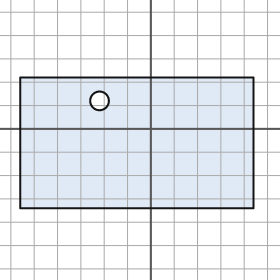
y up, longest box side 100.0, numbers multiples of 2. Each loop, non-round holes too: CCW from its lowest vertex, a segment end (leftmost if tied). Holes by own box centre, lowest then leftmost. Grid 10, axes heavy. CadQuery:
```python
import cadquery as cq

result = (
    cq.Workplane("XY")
    .moveTo(-56.0, -34.0)
    .lineTo(44.0, -34.0)
    .lineTo(44.0, 22.0)
    .lineTo(-56.0, 22.0)
    .close()
    .moveTo(-22.0, 12.0)
    .circle(4.0)
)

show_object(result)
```